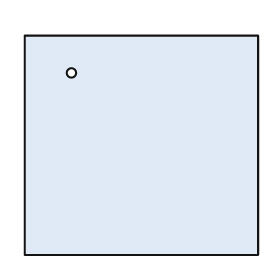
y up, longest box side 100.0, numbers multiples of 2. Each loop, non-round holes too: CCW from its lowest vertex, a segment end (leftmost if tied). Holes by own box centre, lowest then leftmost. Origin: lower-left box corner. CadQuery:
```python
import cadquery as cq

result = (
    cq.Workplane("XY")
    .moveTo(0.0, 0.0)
    .lineTo(100.0, 0.0)
    .lineTo(100.0, 94.0)
    .lineTo(0.0, 94.0)
    .close()
    .moveTo(20.0, 78.0)
    .circle(2.0)
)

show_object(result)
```